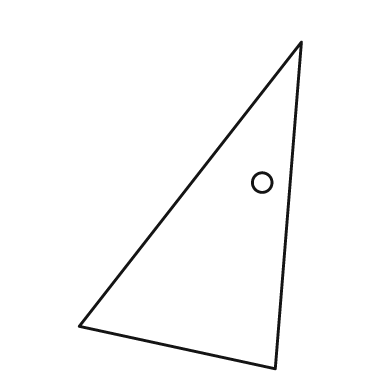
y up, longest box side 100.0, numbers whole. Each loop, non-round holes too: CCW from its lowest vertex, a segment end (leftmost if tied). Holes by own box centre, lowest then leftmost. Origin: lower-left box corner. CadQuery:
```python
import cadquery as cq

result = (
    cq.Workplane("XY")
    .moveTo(60.0, 0.0)
    .lineTo(68.0, 100.0)
    .lineTo(0.0, 13.0)
    .close()
    .moveTo(56.0, 57.0)
    .circle(3.0)
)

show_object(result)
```